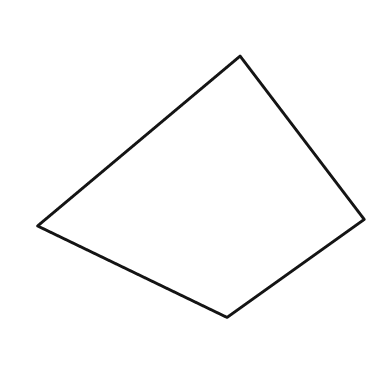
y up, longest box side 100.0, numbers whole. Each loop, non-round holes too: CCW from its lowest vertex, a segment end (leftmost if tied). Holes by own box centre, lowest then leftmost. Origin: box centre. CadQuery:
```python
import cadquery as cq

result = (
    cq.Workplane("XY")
    .moveTo(8.0, -40.0)
    .lineTo(50.0, -10.0)
    .lineTo(12.0, 40.0)
    .lineTo(-50.0, -12.0)
    .close()
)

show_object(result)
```